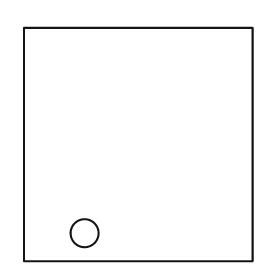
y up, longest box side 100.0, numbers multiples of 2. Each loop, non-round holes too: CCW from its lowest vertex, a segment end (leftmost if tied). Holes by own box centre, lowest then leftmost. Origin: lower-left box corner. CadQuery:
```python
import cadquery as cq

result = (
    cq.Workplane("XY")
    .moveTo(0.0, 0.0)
    .lineTo(98.0, 0.0)
    .lineTo(98.0, 100.0)
    .lineTo(0.0, 100.0)
    .close()
    .moveTo(26.0, 12.0)
    .circle(6.0)
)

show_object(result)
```